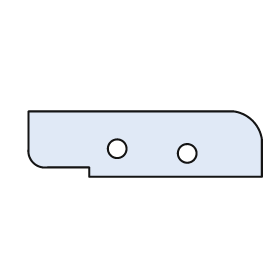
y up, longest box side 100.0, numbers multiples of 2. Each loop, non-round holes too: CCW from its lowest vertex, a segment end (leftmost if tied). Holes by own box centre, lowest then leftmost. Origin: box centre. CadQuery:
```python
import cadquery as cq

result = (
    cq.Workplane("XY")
    .moveTo(-24.0, -14.0)
    .lineTo(50.0, -14.0)
    .lineTo(50.0, 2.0)
    .threePointArc((46.0, 10.0), (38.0, 14.0))
    .lineTo(-50.0, 14.0)
    .lineTo(-50.0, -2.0)
    .threePointArc((-48.0, -8.0), (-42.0, -10.0))
    .lineTo(-24.0, -10.0)
    .close()
    .moveTo(18.0, -4.0)
    .circle(4.0)
    .moveTo(-12.0, -2.0)
    .circle(4.0)
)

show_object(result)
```